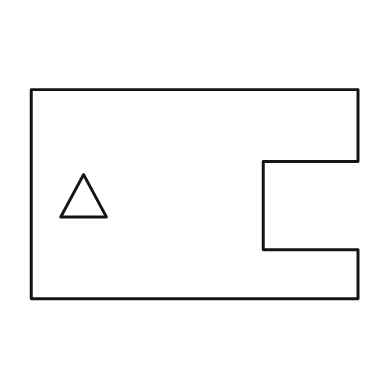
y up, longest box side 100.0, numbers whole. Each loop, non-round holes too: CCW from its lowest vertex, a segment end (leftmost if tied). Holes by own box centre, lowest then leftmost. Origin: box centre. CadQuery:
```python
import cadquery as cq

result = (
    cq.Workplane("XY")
    .moveTo(-50.0, -32.0)
    .lineTo(50.0, -32.0)
    .lineTo(50.0, -17.0)
    .lineTo(21.0, -17.0)
    .lineTo(21.0, 10.0)
    .lineTo(50.0, 10.0)
    .lineTo(50.0, 32.0)
    .lineTo(-50.0, 32.0)
    .close()
    .moveTo(-41.0, -7.0)
    .lineTo(-27.0, -7.0)
    .lineTo(-34.0, 6.0)
    .close()
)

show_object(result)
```